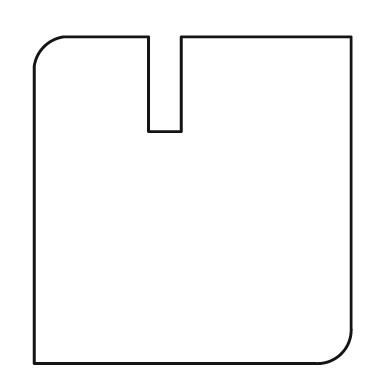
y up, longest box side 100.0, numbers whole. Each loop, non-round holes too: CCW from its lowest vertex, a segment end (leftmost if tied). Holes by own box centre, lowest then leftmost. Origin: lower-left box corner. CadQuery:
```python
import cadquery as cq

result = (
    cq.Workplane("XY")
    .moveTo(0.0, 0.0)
    .lineTo(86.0, 0.0)
    .threePointArc((94.0, 3.0), (97.0, 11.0))
    .lineTo(97.0, 100.0)
    .lineTo(45.0, 100.0)
    .lineTo(45.0, 71.0)
    .lineTo(35.0, 71.0)
    .lineTo(35.0, 100.0)
    .lineTo(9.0, 100.0)
    .threePointArc((3.0, 97.0), (0.0, 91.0))
    .close()
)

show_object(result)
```